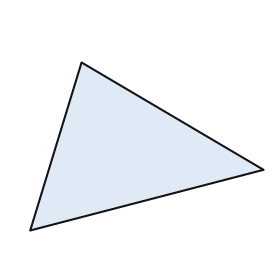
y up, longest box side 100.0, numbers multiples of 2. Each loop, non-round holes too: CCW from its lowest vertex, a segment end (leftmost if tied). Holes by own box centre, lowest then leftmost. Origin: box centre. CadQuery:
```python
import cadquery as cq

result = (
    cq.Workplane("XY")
    .moveTo(-50.0, -36.0)
    .lineTo(50.0, -10.0)
    .lineTo(-28.0, 36.0)
    .close()
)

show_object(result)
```